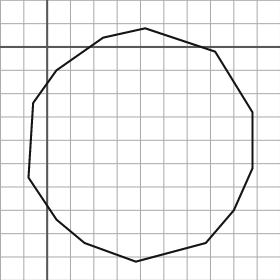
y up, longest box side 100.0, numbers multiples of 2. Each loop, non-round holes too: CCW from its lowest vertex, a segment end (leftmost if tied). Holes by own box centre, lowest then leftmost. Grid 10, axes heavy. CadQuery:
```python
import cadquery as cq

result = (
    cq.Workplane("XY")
    .moveTo(38.0, -92.0)
    .lineTo(68.0, -84.0)
    .lineTo(80.0, -70.0)
    .lineTo(88.0, -52.0)
    .lineTo(88.0, -28.0)
    .lineTo(72.0, -2.0)
    .lineTo(42.0, 8.0)
    .lineTo(24.0, 4.0)
    .lineTo(4.0, -10.0)
    .lineTo(-6.0, -24.0)
    .lineTo(-8.0, -56.0)
    .lineTo(4.0, -74.0)
    .lineTo(16.0, -84.0)
    .close()
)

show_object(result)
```